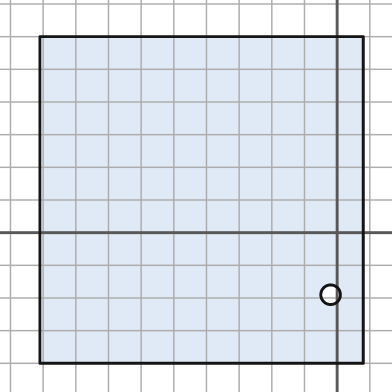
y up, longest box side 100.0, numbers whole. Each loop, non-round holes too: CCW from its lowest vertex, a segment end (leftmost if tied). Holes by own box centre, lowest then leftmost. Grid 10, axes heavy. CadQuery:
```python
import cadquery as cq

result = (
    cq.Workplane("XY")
    .moveTo(-91.0, -40.0)
    .lineTo(8.0, -40.0)
    .lineTo(8.0, 60.0)
    .lineTo(-91.0, 60.0)
    .close()
    .moveTo(-2.0, -19.0)
    .circle(3.0)
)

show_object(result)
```